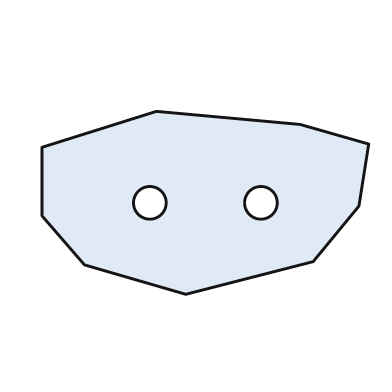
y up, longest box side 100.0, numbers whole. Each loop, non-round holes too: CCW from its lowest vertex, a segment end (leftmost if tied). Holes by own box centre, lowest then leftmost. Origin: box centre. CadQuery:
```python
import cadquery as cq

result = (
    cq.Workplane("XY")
    .moveTo(-6.0, -28.0)
    .lineTo(33.0, -18.0)
    .lineTo(47.0, -1.0)
    .lineTo(50.0, 18.0)
    .lineTo(29.0, 24.0)
    .lineTo(-15.0, 28.0)
    .lineTo(-50.0, 17.0)
    .lineTo(-50.0, -4.0)
    .lineTo(-37.0, -19.0)
    .close()
    .moveTo(-17.0, 0.0)
    .circle(5.0)
    .moveTo(17.0, 0.0)
    .circle(5.0)
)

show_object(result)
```